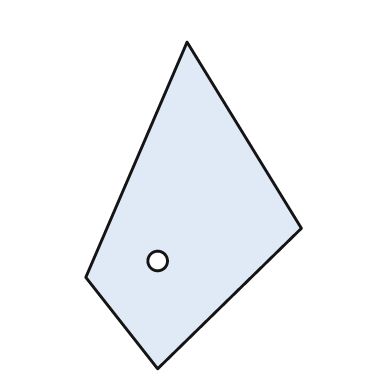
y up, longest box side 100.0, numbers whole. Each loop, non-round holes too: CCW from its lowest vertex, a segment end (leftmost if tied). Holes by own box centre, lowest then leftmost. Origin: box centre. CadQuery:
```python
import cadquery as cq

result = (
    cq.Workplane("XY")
    .moveTo(-11.0, -50.0)
    .lineTo(33.0, -7.0)
    .lineTo(-2.0, 50.0)
    .lineTo(-33.0, -22.0)
    .close()
    .moveTo(-11.0, -17.0)
    .circle(3.0)
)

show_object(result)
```